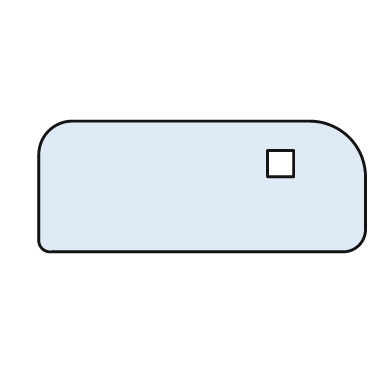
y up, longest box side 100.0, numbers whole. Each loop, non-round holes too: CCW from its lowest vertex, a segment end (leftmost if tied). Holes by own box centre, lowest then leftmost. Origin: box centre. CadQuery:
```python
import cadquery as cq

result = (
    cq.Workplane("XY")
    .moveTo(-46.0, -20.0)
    .lineTo(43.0, -20.0)
    .threePointArc((48.0, -18.0), (50.0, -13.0))
    .lineTo(50.0, 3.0)
    .threePointArc((45.0, 15.0), (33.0, 20.0))
    .lineTo(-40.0, 20.0)
    .threePointArc((-47.0, 17.0), (-50.0, 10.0))
    .lineTo(-50.0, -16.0)
    .threePointArc((-49.0, -19.0), (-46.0, -20.0))
    .close()
    .moveTo(20.0, 3.0)
    .lineTo(28.0, 3.0)
    .lineTo(28.0, 11.0)
    .lineTo(20.0, 11.0)
    .close()
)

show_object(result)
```